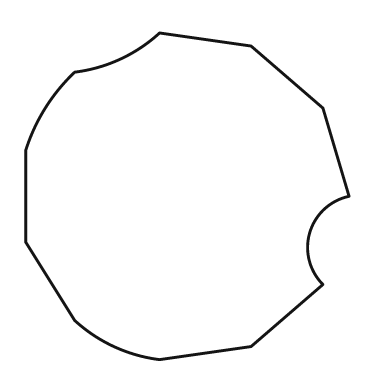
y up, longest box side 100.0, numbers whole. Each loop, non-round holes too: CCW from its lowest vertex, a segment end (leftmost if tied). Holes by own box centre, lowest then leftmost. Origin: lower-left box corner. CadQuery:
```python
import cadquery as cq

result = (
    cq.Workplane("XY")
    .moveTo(41.0, 0.0)
    .lineTo(69.0, 4.0)
    .lineTo(91.0, 23.0)
    .threePointArc((87.0, 39.0), (99.0, 50.0))
    .lineTo(91.0, 77.0)
    .lineTo(69.0, 96.0)
    .lineTo(41.0, 100.0)
    .threePointArc((29.0, 92.0), (15.0, 88.0))
    .threePointArc((6.0, 77.0), (0.0, 64.0))
    .lineTo(0.0, 36.0)
    .lineTo(15.0, 12.0)
    .threePointArc((27.0, 4.0), (41.0, 0.0))
    .close()
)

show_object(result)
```